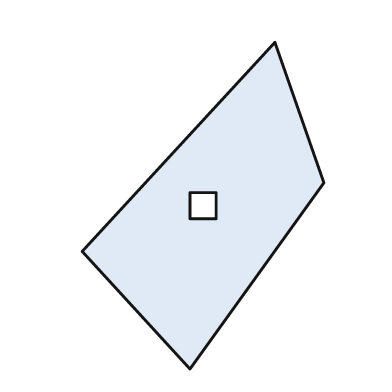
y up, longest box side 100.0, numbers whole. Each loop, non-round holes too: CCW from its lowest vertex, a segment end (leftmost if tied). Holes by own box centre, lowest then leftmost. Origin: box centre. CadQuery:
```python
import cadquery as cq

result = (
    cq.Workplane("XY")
    .moveTo(-4.0, -50.0)
    .lineTo(37.0, 7.0)
    .lineTo(22.0, 50.0)
    .lineTo(-37.0, -14.0)
    .close()
    .moveTo(-4.0, -4.0)
    .lineTo(4.0, -4.0)
    .lineTo(4.0, 4.0)
    .lineTo(-4.0, 4.0)
    .close()
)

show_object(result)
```